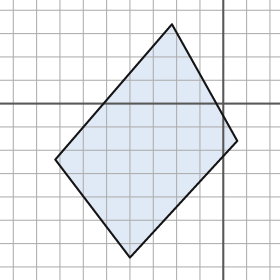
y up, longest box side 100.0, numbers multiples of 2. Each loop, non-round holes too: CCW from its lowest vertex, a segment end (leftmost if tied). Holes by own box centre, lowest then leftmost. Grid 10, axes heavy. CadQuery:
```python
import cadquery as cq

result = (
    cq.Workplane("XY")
    .moveTo(-40.0, -66.0)
    .lineTo(6.0, -16.0)
    .lineTo(-22.0, 34.0)
    .lineTo(-72.0, -24.0)
    .close()
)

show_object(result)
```